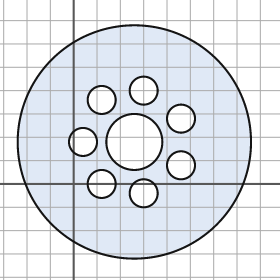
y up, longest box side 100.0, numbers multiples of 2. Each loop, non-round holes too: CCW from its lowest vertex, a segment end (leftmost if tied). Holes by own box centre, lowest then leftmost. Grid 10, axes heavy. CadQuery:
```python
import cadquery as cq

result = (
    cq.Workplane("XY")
    .moveTo(26.0, 18.0)
    .circle(50.0)
    .moveTo(30.0, -4.0)
    .circle(6.0)
    .moveTo(12.0, 0.0)
    .circle(6.0)
    .moveTo(46.0, 8.0)
    .circle(6.0)
    .moveTo(4.0, 18.0)
    .circle(6.0)
    .moveTo(26.0, 18.0)
    .circle(12.0)
    .moveTo(46.0, 28.0)
    .circle(6.0)
    .moveTo(12.0, 36.0)
    .circle(6.0)
    .moveTo(30.0, 40.0)
    .circle(6.0)
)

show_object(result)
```